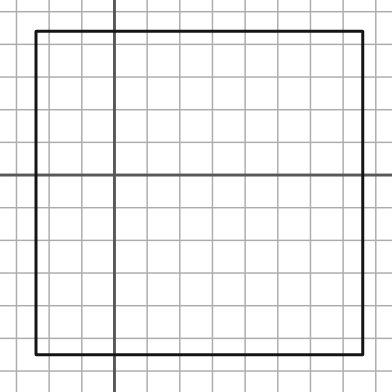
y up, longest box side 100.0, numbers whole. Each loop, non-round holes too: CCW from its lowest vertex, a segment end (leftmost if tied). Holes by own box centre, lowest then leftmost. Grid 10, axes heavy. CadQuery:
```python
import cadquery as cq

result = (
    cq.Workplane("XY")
    .moveTo(-24.0, -55.0)
    .lineTo(76.0, -55.0)
    .lineTo(76.0, 44.0)
    .lineTo(-24.0, 44.0)
    .close()
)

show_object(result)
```